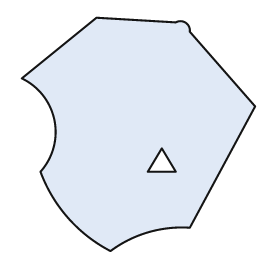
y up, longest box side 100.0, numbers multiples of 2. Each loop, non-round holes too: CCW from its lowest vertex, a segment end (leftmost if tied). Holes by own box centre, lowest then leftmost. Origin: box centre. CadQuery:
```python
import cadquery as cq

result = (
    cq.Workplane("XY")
    .moveTo(-12.0, -50.0)
    .threePointArc((4.0, -42.0), (22.0, -40.0))
    .lineTo(50.0, 12.0)
    .lineTo(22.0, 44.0)
    .threePointArc((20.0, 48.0), (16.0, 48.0))
    .lineTo(-18.0, 50.0)
    .lineTo(-50.0, 24.0)
    .threePointArc((-36.0, 6.0), (-42.0, -16.0))
    .threePointArc((-30.0, -36.0), (-12.0, -50.0))
    .close()
    .moveTo(4.0, -16.0)
    .lineTo(16.0, -16.0)
    .lineTo(10.0, -6.0)
    .close()
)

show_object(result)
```